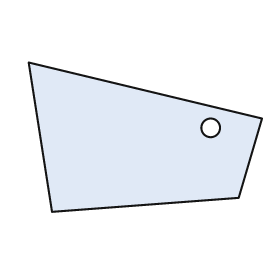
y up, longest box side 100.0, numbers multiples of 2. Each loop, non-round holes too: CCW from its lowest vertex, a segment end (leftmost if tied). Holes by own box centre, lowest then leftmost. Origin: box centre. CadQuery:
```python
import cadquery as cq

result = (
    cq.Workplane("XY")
    .moveTo(-40.0, -32.0)
    .lineTo(40.0, -26.0)
    .lineTo(50.0, 8.0)
    .lineTo(-50.0, 32.0)
    .close()
    .moveTo(28.0, 4.0)
    .circle(4.0)
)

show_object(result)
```